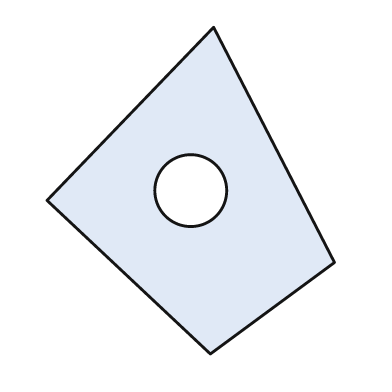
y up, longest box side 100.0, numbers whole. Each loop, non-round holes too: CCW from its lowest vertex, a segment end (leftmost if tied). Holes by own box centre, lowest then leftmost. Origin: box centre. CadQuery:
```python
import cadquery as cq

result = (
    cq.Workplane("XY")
    .moveTo(6.0, -50.0)
    .lineTo(44.0, -22.0)
    .lineTo(7.0, 50.0)
    .lineTo(-44.0, -3.0)
    .close()
    .moveTo(0.0, 0.0)
    .circle(11.0)
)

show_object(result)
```